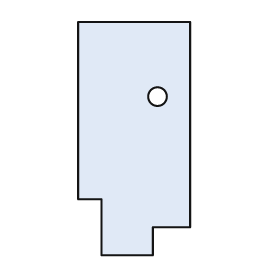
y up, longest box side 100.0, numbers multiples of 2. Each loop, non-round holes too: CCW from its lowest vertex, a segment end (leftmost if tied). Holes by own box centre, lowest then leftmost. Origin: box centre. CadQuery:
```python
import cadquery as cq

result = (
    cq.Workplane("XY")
    .moveTo(-14.0, -50.0)
    .lineTo(8.0, -50.0)
    .lineTo(8.0, -38.0)
    .lineTo(24.0, -38.0)
    .lineTo(24.0, 50.0)
    .lineTo(-24.0, 50.0)
    .lineTo(-24.0, -26.0)
    .lineTo(-14.0, -26.0)
    .close()
    .moveTo(10.0, 18.0)
    .circle(4.0)
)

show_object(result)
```